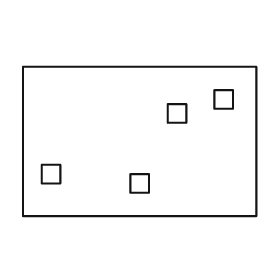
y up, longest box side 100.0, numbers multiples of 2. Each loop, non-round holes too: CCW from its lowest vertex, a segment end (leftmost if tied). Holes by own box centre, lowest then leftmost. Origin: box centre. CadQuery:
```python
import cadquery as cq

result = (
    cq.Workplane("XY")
    .moveTo(-50.0, -32.0)
    .lineTo(50.0, -32.0)
    .lineTo(50.0, 32.0)
    .lineTo(-50.0, 32.0)
    .close()
    .moveTo(-4.0, -22.0)
    .lineTo(4.0, -22.0)
    .lineTo(4.0, -14.0)
    .lineTo(-4.0, -14.0)
    .close()
    .moveTo(-42.0, -18.0)
    .lineTo(-34.0, -18.0)
    .lineTo(-34.0, -10.0)
    .lineTo(-42.0, -10.0)
    .close()
    .moveTo(12.0, 8.0)
    .lineTo(20.0, 8.0)
    .lineTo(20.0, 16.0)
    .lineTo(12.0, 16.0)
    .close()
    .moveTo(32.0, 14.0)
    .lineTo(40.0, 14.0)
    .lineTo(40.0, 22.0)
    .lineTo(32.0, 22.0)
    .close()
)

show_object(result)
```